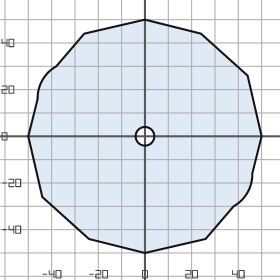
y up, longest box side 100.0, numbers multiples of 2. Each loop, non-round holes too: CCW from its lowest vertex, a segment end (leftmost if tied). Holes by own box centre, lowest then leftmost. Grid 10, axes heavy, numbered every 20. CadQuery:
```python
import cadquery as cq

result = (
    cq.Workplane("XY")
    .moveTo(0.0, -50.0)
    .lineTo(26.0, -44.0)
    .lineTo(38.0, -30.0)
    .threePointArc((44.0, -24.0), (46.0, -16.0))
    .lineTo(50.0, 0.0)
    .lineTo(44.0, 26.0)
    .lineTo(24.0, 44.0)
    .lineTo(0.0, 50.0)
    .lineTo(-26.0, 44.0)
    .lineTo(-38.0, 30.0)
    .threePointArc((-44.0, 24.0), (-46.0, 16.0))
    .lineTo(-50.0, 0.0)
    .lineTo(-44.0, -26.0)
    .lineTo(-24.0, -44.0)
    .close()
    .moveTo(0.0, 0.0)
    .circle(4.0)
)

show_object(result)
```